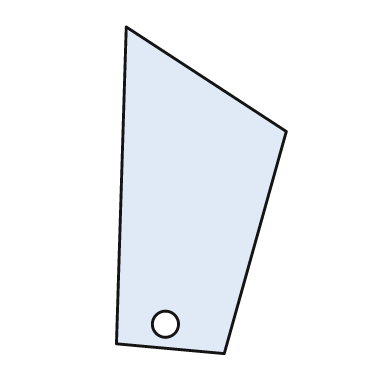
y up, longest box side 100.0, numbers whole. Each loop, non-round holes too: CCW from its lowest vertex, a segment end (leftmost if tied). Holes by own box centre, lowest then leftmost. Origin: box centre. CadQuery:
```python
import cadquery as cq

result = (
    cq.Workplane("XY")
    .moveTo(7.0, -50.0)
    .lineTo(26.0, 18.0)
    .lineTo(-23.0, 50.0)
    .lineTo(-26.0, -47.0)
    .close()
    .moveTo(-11.0, -41.0)
    .circle(4.0)
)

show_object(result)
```